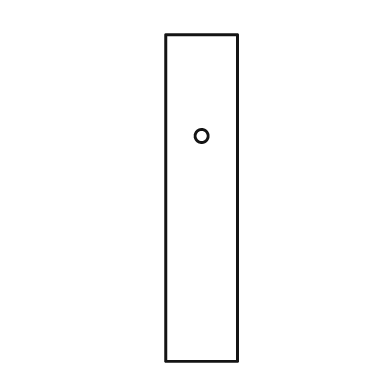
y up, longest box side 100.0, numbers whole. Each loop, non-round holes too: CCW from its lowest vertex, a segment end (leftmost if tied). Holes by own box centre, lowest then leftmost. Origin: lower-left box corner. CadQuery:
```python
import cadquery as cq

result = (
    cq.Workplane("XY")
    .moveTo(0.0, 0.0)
    .lineTo(22.0, 0.0)
    .lineTo(22.0, 100.0)
    .lineTo(0.0, 100.0)
    .close()
    .moveTo(11.0, 69.0)
    .circle(2.0)
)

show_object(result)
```